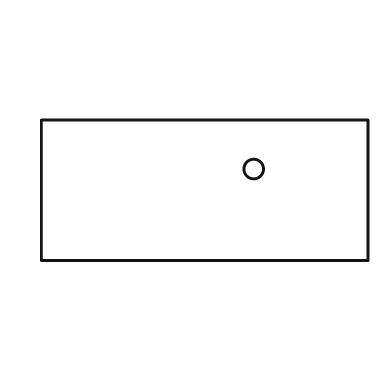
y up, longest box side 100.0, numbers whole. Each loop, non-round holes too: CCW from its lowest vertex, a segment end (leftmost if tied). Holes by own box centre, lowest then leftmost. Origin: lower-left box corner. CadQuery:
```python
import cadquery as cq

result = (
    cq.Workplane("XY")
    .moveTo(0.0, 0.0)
    .lineTo(100.0, 0.0)
    .lineTo(100.0, 43.0)
    .lineTo(0.0, 43.0)
    .close()
    .moveTo(65.0, 28.0)
    .circle(3.0)
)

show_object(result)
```